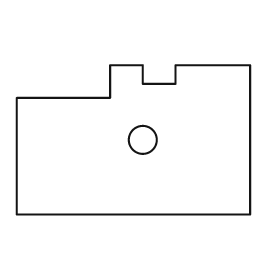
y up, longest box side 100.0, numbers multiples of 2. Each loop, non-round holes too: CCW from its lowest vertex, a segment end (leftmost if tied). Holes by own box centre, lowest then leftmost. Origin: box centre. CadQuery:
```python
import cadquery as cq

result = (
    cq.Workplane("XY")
    .moveTo(-50.0, -32.0)
    .lineTo(50.0, -32.0)
    .lineTo(50.0, 32.0)
    .lineTo(18.0, 32.0)
    .lineTo(18.0, 24.0)
    .lineTo(4.0, 24.0)
    .lineTo(4.0, 32.0)
    .lineTo(-10.0, 32.0)
    .lineTo(-10.0, 18.0)
    .lineTo(-50.0, 18.0)
    .close()
    .moveTo(4.0, 0.0)
    .circle(6.0)
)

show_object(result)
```